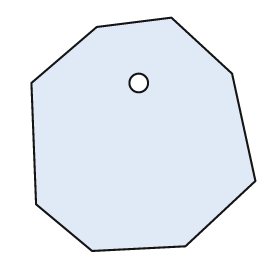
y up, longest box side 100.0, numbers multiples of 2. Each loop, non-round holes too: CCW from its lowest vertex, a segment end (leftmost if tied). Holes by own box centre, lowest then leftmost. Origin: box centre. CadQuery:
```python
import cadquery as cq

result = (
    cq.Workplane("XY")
    .moveTo(-22.0, -50.0)
    .lineTo(18.0, -48.0)
    .lineTo(48.0, -20.0)
    .lineTo(38.0, 26.0)
    .lineTo(12.0, 50.0)
    .lineTo(-20.0, 46.0)
    .lineTo(-48.0, 22.0)
    .lineTo(-46.0, -30.0)
    .close()
    .moveTo(-2.0, 22.0)
    .circle(4.0)
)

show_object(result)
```